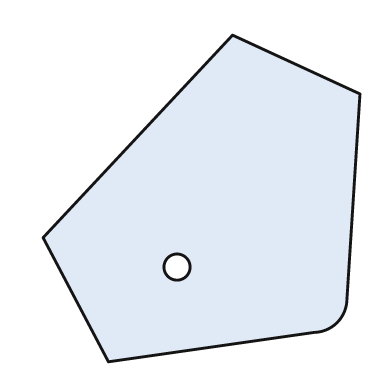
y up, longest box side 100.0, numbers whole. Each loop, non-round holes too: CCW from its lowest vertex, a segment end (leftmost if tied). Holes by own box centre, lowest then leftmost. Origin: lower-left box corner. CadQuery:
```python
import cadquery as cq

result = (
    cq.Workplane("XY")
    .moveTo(20.0, 0.0)
    .lineTo(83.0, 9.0)
    .threePointArc((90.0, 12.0), (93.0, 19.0))
    .lineTo(97.0, 82.0)
    .lineTo(58.0, 100.0)
    .lineTo(0.0, 38.0)
    .close()
    .moveTo(41.0, 29.0)
    .circle(4.0)
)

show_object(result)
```